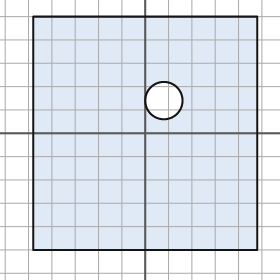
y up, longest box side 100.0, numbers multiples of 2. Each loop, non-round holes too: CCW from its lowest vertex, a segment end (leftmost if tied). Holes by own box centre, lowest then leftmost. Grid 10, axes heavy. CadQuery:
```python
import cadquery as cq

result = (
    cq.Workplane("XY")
    .moveTo(-48.0, -50.0)
    .lineTo(48.0, -50.0)
    .lineTo(48.0, 50.0)
    .lineTo(-48.0, 50.0)
    .close()
    .moveTo(8.0, 14.0)
    .circle(8.0)
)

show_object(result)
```